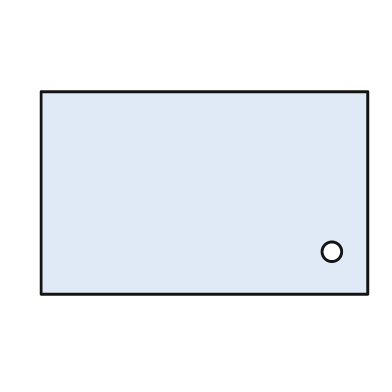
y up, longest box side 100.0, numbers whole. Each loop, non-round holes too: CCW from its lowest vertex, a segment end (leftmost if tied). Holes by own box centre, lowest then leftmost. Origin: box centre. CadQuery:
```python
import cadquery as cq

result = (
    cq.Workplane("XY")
    .moveTo(-50.0, -31.0)
    .lineTo(50.0, -31.0)
    .lineTo(50.0, 31.0)
    .lineTo(-50.0, 31.0)
    .close()
    .moveTo(39.0, -18.0)
    .circle(3.0)
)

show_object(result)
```